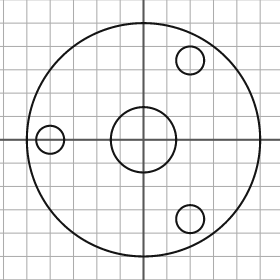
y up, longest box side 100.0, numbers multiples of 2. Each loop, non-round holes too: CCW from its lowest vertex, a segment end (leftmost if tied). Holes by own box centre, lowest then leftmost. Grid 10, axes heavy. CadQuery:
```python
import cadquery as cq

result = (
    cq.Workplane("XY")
    .moveTo(0.0, 0.0)
    .circle(50.0)
    .moveTo(20.0, -34.0)
    .circle(6.0)
    .moveTo(-40.0, 0.0)
    .circle(6.0)
    .moveTo(0.0, 0.0)
    .circle(14.0)
    .moveTo(20.0, 34.0)
    .circle(6.0)
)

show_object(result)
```